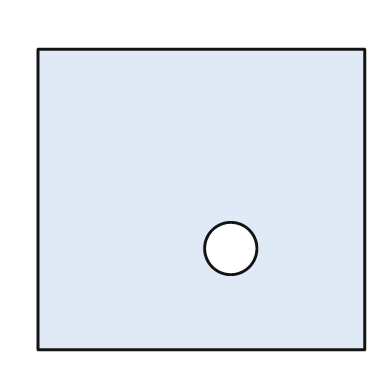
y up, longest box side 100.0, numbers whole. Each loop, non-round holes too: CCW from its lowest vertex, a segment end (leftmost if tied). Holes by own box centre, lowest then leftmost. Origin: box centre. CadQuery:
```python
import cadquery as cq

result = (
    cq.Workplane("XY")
    .moveTo(-50.0, -46.0)
    .lineTo(50.0, -46.0)
    .lineTo(50.0, 46.0)
    .lineTo(-50.0, 46.0)
    .close()
    .moveTo(9.0, -15.0)
    .circle(8.0)
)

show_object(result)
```